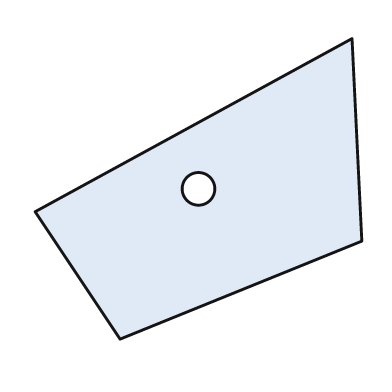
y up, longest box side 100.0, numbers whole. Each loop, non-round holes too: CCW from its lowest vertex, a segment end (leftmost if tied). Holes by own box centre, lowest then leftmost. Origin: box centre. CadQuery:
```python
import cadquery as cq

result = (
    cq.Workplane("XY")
    .moveTo(-24.0, -46.0)
    .lineTo(50.0, -16.0)
    .lineTo(47.0, 46.0)
    .lineTo(-50.0, -7.0)
    .close()
    .moveTo(0.0, 0.0)
    .circle(5.0)
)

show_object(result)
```